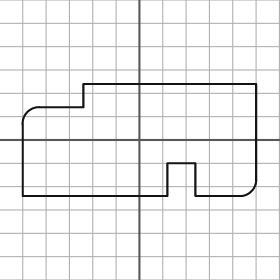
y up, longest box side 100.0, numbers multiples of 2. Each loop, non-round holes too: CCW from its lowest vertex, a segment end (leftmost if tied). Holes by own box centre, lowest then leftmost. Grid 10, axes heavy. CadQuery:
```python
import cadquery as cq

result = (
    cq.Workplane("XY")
    .moveTo(-50.0, -24.0)
    .lineTo(12.0, -24.0)
    .lineTo(12.0, -10.0)
    .lineTo(24.0, -10.0)
    .lineTo(24.0, -24.0)
    .lineTo(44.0, -24.0)
    .threePointArc((48.0, -22.0), (50.0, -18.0))
    .lineTo(50.0, 24.0)
    .lineTo(-24.0, 24.0)
    .lineTo(-24.0, 14.0)
    .lineTo(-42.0, 14.0)
    .threePointArc((-48.0, 12.0), (-50.0, 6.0))
    .close()
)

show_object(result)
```